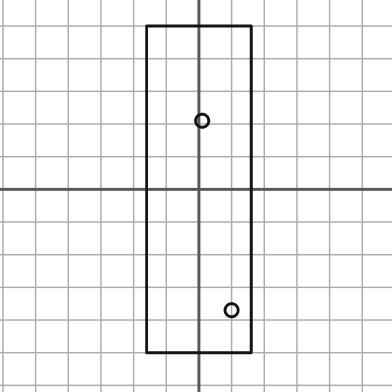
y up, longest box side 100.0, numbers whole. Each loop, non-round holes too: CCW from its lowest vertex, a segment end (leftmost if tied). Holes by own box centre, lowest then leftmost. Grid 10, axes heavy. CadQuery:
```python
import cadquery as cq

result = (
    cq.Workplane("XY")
    .moveTo(-16.0, -50.0)
    .lineTo(16.0, -50.0)
    .lineTo(16.0, 50.0)
    .lineTo(-16.0, 50.0)
    .close()
    .moveTo(10.0, -37.0)
    .circle(2.0)
    .moveTo(1.0, 21.0)
    .circle(2.0)
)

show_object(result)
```